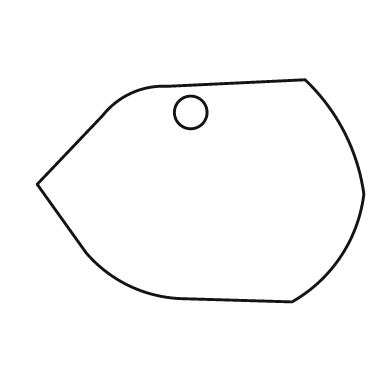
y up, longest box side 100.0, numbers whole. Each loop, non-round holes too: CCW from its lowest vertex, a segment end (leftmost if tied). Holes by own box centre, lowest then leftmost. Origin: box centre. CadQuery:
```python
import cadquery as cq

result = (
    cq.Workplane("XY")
    .moveTo(28.0, -34.0)
    .threePointArc((43.0, -20.0), (50.0, -1.0))
    .threePointArc((44.0, 18.0), (32.0, 34.0))
    .lineTo(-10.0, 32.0)
    .threePointArc((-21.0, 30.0), (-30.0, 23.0))
    .lineTo(-50.0, 2.0)
    .lineTo(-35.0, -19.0)
    .threePointArc((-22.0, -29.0), (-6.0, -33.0))
    .close()
    .moveTo(-3.0, 24.0)
    .circle(5.0)
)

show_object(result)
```